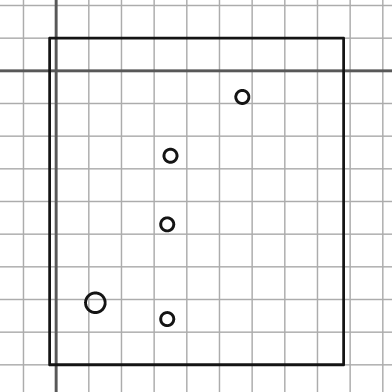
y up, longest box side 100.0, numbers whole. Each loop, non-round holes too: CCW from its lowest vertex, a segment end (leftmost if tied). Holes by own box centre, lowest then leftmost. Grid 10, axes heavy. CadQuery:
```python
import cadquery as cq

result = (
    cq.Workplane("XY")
    .moveTo(-2.0, -90.0)
    .lineTo(88.0, -90.0)
    .lineTo(88.0, 10.0)
    .lineTo(-2.0, 10.0)
    .close()
    .moveTo(34.0, -76.0)
    .circle(2.0)
    .moveTo(12.0, -71.0)
    .circle(3.0)
    .moveTo(34.0, -47.0)
    .circle(2.0)
    .moveTo(35.0, -26.0)
    .circle(2.0)
    .moveTo(57.0, -8.0)
    .circle(2.0)
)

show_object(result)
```